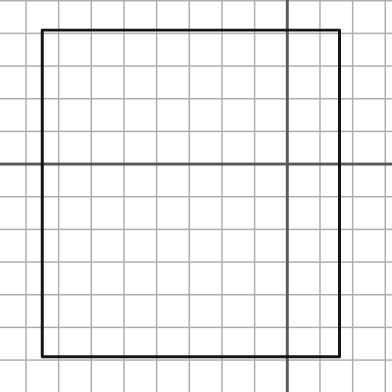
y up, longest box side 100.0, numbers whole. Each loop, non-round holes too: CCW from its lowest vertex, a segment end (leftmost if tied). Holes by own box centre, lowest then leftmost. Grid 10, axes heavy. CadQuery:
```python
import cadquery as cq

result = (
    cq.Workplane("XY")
    .moveTo(-75.0, -59.0)
    .lineTo(16.0, -59.0)
    .lineTo(16.0, 41.0)
    .lineTo(-75.0, 41.0)
    .close()
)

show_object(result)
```